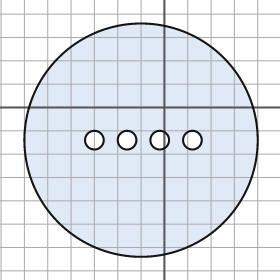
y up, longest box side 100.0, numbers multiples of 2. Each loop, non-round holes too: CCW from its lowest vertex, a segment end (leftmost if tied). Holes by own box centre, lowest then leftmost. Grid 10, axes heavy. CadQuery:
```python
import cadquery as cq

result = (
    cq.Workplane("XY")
    .moveTo(-10.0, -14.0)
    .circle(50.0)
    .moveTo(-30.0, -14.0)
    .circle(4.0)
    .moveTo(-16.0, -14.0)
    .circle(4.0)
    .moveTo(-2.0, -14.0)
    .circle(4.0)
    .moveTo(12.0, -14.0)
    .circle(4.0)
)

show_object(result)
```